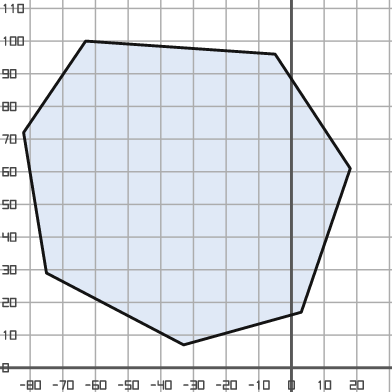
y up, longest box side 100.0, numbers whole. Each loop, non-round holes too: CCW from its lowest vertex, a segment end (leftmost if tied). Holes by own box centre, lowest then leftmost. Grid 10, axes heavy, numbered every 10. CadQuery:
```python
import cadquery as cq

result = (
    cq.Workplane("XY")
    .moveTo(-33.0, 7.0)
    .lineTo(3.0, 17.0)
    .lineTo(18.0, 61.0)
    .lineTo(-5.0, 96.0)
    .lineTo(-63.0, 100.0)
    .lineTo(-82.0, 72.0)
    .lineTo(-75.0, 29.0)
    .close()
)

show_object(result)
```